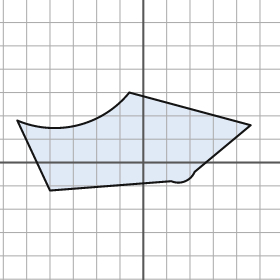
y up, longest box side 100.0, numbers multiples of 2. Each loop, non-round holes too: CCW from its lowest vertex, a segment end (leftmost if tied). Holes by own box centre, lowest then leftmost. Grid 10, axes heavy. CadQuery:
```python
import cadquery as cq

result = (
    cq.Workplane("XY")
    .moveTo(-40.0, -12.0)
    .lineTo(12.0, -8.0)
    .threePointArc((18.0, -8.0), (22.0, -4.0))
    .lineTo(46.0, 16.0)
    .lineTo(-6.0, 30.0)
    .threePointArc((-28.0, 16.0), (-54.0, 18.0))
    .close()
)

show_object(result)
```